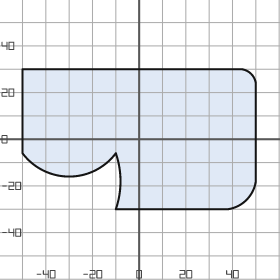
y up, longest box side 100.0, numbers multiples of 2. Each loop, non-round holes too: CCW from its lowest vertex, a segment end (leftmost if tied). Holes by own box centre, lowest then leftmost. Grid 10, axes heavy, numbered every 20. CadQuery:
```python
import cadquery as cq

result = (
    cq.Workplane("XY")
    .moveTo(-10.0, -30.0)
    .lineTo(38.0, -30.0)
    .threePointArc((46.0, -26.0), (50.0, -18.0))
    .lineTo(50.0, 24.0)
    .threePointArc((48.0, 28.0), (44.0, 30.0))
    .lineTo(-50.0, 30.0)
    .lineTo(-50.0, -6.0)
    .threePointArc((-30.0, -16.0), (-10.0, -6.0))
    .threePointArc((-8.0, -18.0), (-10.0, -30.0))
    .close()
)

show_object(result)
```